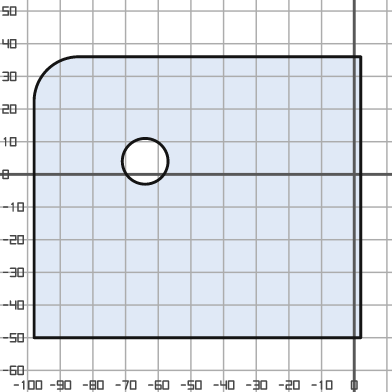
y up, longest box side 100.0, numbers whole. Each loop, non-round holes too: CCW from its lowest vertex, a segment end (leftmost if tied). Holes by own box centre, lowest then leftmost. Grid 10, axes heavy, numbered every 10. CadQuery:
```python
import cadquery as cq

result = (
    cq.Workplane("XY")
    .moveTo(-98.0, -50.0)
    .lineTo(2.0, -50.0)
    .lineTo(2.0, 36.0)
    .lineTo(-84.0, 36.0)
    .threePointArc((-94.0, 32.0), (-98.0, 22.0))
    .close()
    .moveTo(-64.0, 4.0)
    .circle(7.0)
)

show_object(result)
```